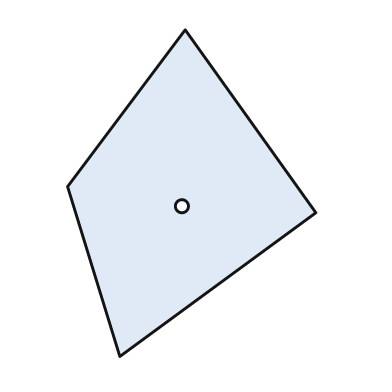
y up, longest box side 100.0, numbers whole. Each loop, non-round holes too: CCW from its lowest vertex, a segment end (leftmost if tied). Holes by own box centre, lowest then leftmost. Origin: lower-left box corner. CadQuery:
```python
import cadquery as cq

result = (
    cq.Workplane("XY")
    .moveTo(16.0, 0.0)
    .lineTo(76.0, 44.0)
    .lineTo(36.0, 100.0)
    .lineTo(0.0, 52.0)
    .close()
    .moveTo(35.0, 46.0)
    .circle(2.0)
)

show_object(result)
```